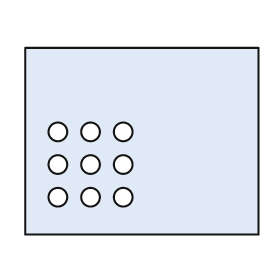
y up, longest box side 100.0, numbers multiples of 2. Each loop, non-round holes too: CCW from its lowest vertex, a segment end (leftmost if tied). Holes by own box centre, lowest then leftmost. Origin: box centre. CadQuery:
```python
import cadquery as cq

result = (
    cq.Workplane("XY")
    .moveTo(-50.0, -40.0)
    .lineTo(50.0, -40.0)
    .lineTo(50.0, 40.0)
    .lineTo(-50.0, 40.0)
    .close()
    .moveTo(-36.0, -24.0)
    .circle(4.0)
    .moveTo(-22.0, -24.0)
    .circle(4.0)
    .moveTo(-8.0, -24.0)
    .circle(4.0)
    .moveTo(-36.0, -10.0)
    .circle(4.0)
    .moveTo(-22.0, -10.0)
    .circle(4.0)
    .moveTo(-8.0, -10.0)
    .circle(4.0)
    .moveTo(-36.0, 4.0)
    .circle(4.0)
    .moveTo(-22.0, 4.0)
    .circle(4.0)
    .moveTo(-8.0, 4.0)
    .circle(4.0)
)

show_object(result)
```